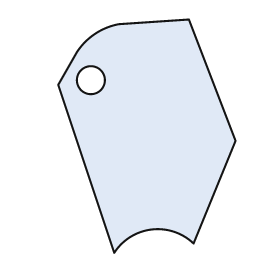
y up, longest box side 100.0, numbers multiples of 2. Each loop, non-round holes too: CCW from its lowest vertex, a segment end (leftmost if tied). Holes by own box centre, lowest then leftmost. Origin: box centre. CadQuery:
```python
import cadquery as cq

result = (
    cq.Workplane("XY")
    .moveTo(-14.0, -50.0)
    .threePointArc((2.0, -40.0), (20.0, -46.0))
    .lineTo(38.0, -2.0)
    .lineTo(18.0, 50.0)
    .lineTo(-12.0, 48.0)
    .threePointArc((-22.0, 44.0), (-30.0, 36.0))
    .lineTo(-38.0, 22.0)
    .close()
    .moveTo(-24.0, 24.0)
    .circle(6.0)
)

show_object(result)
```